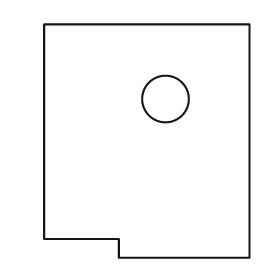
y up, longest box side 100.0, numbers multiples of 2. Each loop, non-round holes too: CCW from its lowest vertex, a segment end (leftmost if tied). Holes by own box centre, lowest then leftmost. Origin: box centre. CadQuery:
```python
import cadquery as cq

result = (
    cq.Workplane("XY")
    .moveTo(-12.0, -50.0)
    .lineTo(44.0, -50.0)
    .lineTo(44.0, 50.0)
    .lineTo(-44.0, 50.0)
    .lineTo(-44.0, -42.0)
    .lineTo(-12.0, -42.0)
    .close()
    .moveTo(8.0, 18.0)
    .circle(10.0)
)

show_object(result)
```